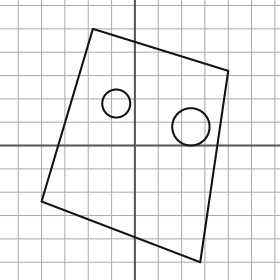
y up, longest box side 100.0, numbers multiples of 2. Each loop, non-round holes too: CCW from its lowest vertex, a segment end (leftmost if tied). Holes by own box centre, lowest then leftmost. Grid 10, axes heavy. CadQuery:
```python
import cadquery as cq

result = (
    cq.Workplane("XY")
    .moveTo(28.0, -50.0)
    .lineTo(40.0, 32.0)
    .lineTo(-18.0, 50.0)
    .lineTo(-40.0, -24.0)
    .close()
    .moveTo(24.0, 8.0)
    .circle(8.0)
    .moveTo(-8.0, 18.0)
    .circle(6.0)
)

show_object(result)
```